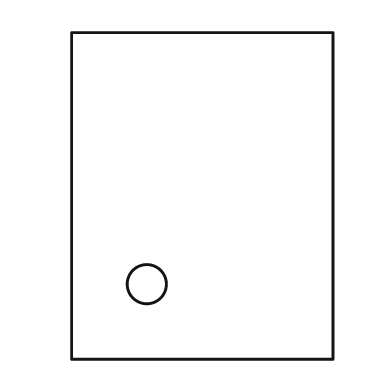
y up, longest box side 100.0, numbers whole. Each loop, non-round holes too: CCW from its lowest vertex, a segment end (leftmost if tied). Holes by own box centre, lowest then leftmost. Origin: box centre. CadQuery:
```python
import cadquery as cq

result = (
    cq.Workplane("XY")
    .moveTo(-40.0, -50.0)
    .lineTo(40.0, -50.0)
    .lineTo(40.0, 50.0)
    .lineTo(-40.0, 50.0)
    .close()
    .moveTo(-17.0, -27.0)
    .circle(6.0)
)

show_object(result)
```